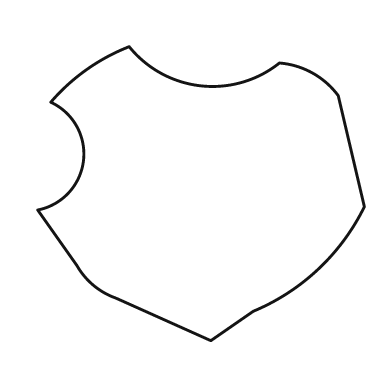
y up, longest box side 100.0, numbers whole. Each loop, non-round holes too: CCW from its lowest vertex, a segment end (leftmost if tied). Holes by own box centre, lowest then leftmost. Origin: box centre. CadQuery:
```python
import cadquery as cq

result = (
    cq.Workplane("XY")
    .moveTo(3.0, -45.0)
    .lineTo(16.0, -36.0)
    .threePointArc((36.0, -23.0), (50.0, -4.0))
    .lineTo(42.0, 30.0)
    .threePointArc((34.0, 37.0), (24.0, 40.0))
    .threePointArc((0.0, 33.0), (-22.0, 45.0))
    .threePointArc((-35.0, 38.0), (-46.0, 28.0))
    .threePointArc((-36.0, 10.0), (-50.0, -5.0))
    .lineTo(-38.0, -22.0)
    .threePointArc((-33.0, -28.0), (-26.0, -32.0))
    .close()
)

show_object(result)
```